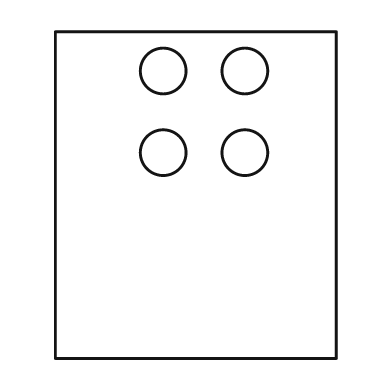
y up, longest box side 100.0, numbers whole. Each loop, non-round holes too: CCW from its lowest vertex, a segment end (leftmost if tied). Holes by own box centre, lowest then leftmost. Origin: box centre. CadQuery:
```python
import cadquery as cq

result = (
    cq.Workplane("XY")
    .moveTo(-43.0, -50.0)
    .lineTo(43.0, -50.0)
    .lineTo(43.0, 50.0)
    .lineTo(-43.0, 50.0)
    .close()
    .moveTo(-10.0, 13.0)
    .circle(7.0)
    .moveTo(15.0, 13.0)
    .circle(7.0)
    .moveTo(-10.0, 38.0)
    .circle(7.0)
    .moveTo(15.0, 38.0)
    .circle(7.0)
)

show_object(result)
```